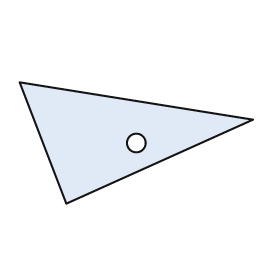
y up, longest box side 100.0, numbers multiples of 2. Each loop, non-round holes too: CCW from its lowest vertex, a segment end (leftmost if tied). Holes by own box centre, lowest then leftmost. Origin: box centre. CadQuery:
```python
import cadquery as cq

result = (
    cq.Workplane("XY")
    .moveTo(-30.0, -26.0)
    .lineTo(50.0, 10.0)
    .lineTo(-50.0, 26.0)
    .close()
    .moveTo(0.0, 0.0)
    .circle(4.0)
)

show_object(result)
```